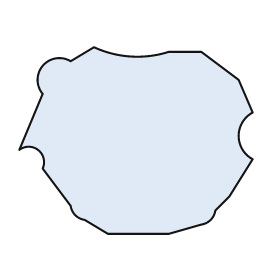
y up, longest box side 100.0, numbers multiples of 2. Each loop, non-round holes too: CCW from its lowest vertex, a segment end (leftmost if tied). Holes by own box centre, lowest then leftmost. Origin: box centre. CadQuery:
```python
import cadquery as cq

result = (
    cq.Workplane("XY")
    .moveTo(-12.0, -40.0)
    .lineTo(14.0, -40.0)
    .lineTo(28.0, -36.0)
    .threePointArc((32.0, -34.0), (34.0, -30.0))
    .lineTo(40.0, -24.0)
    .lineTo(50.0, -8.0)
    .threePointArc((44.0, 2.0), (50.0, 12.0))
    .lineTo(44.0, 26.0)
    .lineTo(28.0, 38.0)
    .lineTo(14.0, 38.0)
    .threePointArc((-2.0, 36.0), (-18.0, 40.0))
    .lineTo(-28.0, 34.0)
    .threePointArc((-40.0, 32.0), (-40.0, 20.0))
    .lineTo(-50.0, -4.0)
    .threePointArc((-42.0, -4.0), (-40.0, -12.0))
    .lineTo(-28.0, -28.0)
    .threePointArc((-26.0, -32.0), (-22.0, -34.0))
    .close()
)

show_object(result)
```